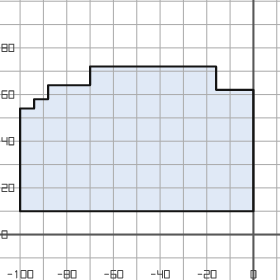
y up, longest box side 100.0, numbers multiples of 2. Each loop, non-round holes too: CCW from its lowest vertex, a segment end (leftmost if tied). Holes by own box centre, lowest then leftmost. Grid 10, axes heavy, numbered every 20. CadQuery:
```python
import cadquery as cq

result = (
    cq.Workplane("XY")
    .moveTo(-100.0, 10.0)
    .lineTo(0.0, 10.0)
    .lineTo(0.0, 62.0)
    .lineTo(-16.0, 62.0)
    .lineTo(-16.0, 72.0)
    .lineTo(-70.0, 72.0)
    .lineTo(-70.0, 64.0)
    .lineTo(-88.0, 64.0)
    .lineTo(-88.0, 58.0)
    .lineTo(-94.0, 58.0)
    .lineTo(-94.0, 54.0)
    .lineTo(-100.0, 54.0)
    .close()
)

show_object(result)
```